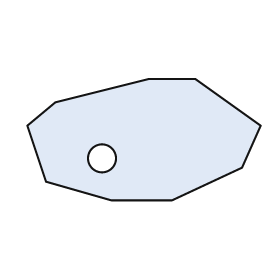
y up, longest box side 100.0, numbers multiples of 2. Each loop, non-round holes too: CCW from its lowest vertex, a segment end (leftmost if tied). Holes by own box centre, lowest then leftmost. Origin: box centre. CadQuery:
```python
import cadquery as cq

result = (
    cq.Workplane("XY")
    .moveTo(-14.0, -26.0)
    .lineTo(12.0, -26.0)
    .lineTo(42.0, -12.0)
    .lineTo(50.0, 6.0)
    .lineTo(22.0, 26.0)
    .lineTo(2.0, 26.0)
    .lineTo(-38.0, 16.0)
    .lineTo(-50.0, 6.0)
    .lineTo(-42.0, -18.0)
    .close()
    .moveTo(-18.0, -8.0)
    .circle(6.0)
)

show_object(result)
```